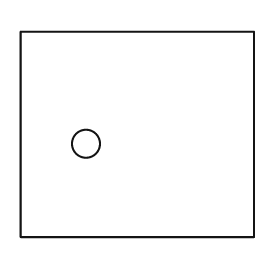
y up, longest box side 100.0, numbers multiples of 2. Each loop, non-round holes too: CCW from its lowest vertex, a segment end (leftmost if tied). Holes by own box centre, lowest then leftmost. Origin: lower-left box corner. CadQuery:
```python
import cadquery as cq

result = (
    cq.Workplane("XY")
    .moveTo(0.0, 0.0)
    .lineTo(100.0, 0.0)
    .lineTo(100.0, 88.0)
    .lineTo(0.0, 88.0)
    .close()
    .moveTo(28.0, 40.0)
    .circle(6.0)
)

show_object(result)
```